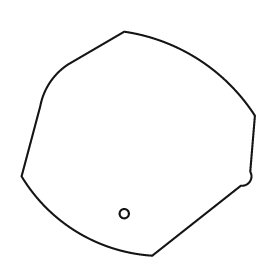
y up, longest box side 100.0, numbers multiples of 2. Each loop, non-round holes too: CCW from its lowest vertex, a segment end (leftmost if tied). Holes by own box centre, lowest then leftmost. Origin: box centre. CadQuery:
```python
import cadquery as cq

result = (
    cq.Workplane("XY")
    .moveTo(6.0, -48.0)
    .lineTo(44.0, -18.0)
    .threePointArc((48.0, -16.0), (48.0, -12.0))
    .lineTo(50.0, 12.0)
    .threePointArc((26.0, 36.0), (-6.0, 48.0))
    .lineTo(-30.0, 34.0)
    .threePointArc((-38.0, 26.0), (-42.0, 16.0))
    .lineTo(-50.0, -14.0)
    .threePointArc((-26.0, -38.0), (6.0, -48.0))
    .close()
    .moveTo(-6.0, -30.0)
    .circle(2.0)
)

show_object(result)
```